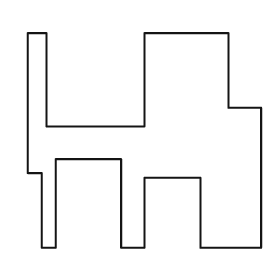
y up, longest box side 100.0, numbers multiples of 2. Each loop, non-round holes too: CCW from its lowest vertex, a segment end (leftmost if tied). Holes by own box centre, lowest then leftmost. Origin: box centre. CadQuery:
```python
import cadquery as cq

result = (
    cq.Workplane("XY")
    .moveTo(-44.0, -46.0)
    .lineTo(-38.0, -46.0)
    .lineTo(-38.0, -8.0)
    .lineTo(-10.0, -8.0)
    .lineTo(-10.0, -46.0)
    .lineTo(0.0, -46.0)
    .lineTo(0.0, -16.0)
    .lineTo(24.0, -16.0)
    .lineTo(24.0, -46.0)
    .lineTo(50.0, -46.0)
    .lineTo(50.0, 14.0)
    .lineTo(36.0, 14.0)
    .lineTo(36.0, 46.0)
    .lineTo(0.0, 46.0)
    .lineTo(0.0, 6.0)
    .lineTo(-42.0, 6.0)
    .lineTo(-42.0, 46.0)
    .lineTo(-50.0, 46.0)
    .lineTo(-50.0, -14.0)
    .lineTo(-44.0, -14.0)
    .close()
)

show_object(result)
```